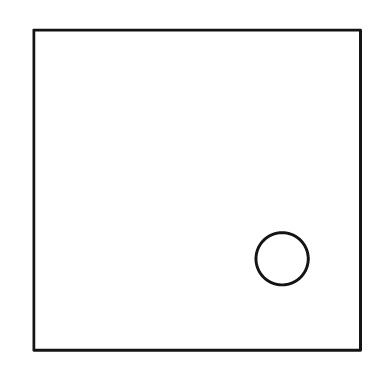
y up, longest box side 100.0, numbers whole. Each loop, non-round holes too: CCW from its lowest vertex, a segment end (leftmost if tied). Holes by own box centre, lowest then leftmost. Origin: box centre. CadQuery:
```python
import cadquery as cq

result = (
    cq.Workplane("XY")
    .moveTo(-50.0, -49.0)
    .lineTo(50.0, -49.0)
    .lineTo(50.0, 49.0)
    .lineTo(-50.0, 49.0)
    .close()
    .moveTo(26.0, -21.0)
    .circle(8.0)
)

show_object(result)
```